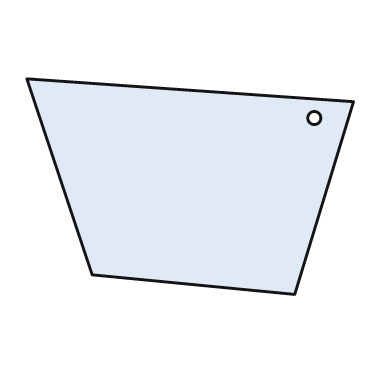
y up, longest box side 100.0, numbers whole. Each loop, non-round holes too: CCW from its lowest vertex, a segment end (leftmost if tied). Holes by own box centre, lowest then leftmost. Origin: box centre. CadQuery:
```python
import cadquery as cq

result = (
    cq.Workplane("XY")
    .moveTo(32.0, -33.0)
    .lineTo(50.0, 26.0)
    .lineTo(-50.0, 33.0)
    .lineTo(-30.0, -27.0)
    .close()
    .moveTo(38.0, 21.0)
    .circle(2.0)
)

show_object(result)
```